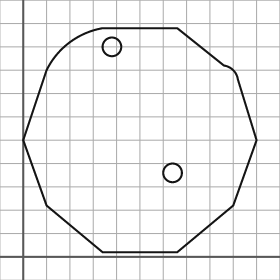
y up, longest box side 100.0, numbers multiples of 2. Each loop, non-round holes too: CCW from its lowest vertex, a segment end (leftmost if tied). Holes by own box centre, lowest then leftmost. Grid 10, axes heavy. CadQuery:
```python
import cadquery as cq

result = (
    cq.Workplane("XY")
    .moveTo(34.0, 2.0)
    .lineTo(66.0, 2.0)
    .lineTo(90.0, 22.0)
    .lineTo(100.0, 50.0)
    .lineTo(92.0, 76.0)
    .threePointArc((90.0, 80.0), (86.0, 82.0))
    .lineTo(66.0, 98.0)
    .lineTo(34.0, 98.0)
    .threePointArc((20.0, 92.0), (10.0, 80.0))
    .lineTo(0.0, 50.0)
    .lineTo(10.0, 22.0)
    .close()
    .moveTo(64.0, 36.0)
    .circle(4.0)
    .moveTo(38.0, 90.0)
    .circle(4.0)
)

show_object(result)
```